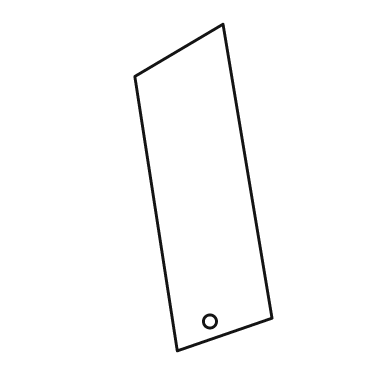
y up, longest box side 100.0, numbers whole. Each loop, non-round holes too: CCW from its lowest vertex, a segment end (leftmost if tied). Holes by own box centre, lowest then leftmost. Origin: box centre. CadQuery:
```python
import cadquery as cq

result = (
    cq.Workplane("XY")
    .moveTo(-8.0, -50.0)
    .lineTo(21.0, -40.0)
    .lineTo(6.0, 50.0)
    .lineTo(-21.0, 34.0)
    .close()
    .moveTo(2.0, -41.0)
    .circle(2.0)
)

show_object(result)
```